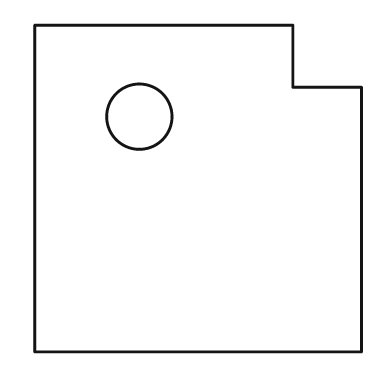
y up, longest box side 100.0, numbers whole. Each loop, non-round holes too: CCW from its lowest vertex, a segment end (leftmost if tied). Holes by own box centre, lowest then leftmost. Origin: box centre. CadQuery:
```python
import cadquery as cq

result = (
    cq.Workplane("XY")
    .moveTo(-50.0, -50.0)
    .lineTo(50.0, -50.0)
    .lineTo(50.0, 31.0)
    .lineTo(29.0, 31.0)
    .lineTo(29.0, 50.0)
    .lineTo(-50.0, 50.0)
    .close()
    .moveTo(-18.0, 22.0)
    .circle(10.0)
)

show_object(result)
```